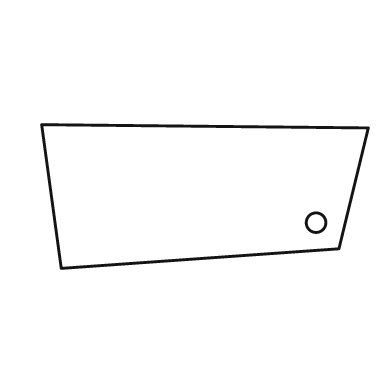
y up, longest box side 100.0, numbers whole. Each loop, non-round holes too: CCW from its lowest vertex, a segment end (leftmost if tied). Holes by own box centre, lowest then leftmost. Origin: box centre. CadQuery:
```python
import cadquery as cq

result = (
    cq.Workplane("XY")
    .moveTo(-44.0, -22.0)
    .lineTo(41.0, -16.0)
    .lineTo(50.0, 21.0)
    .lineTo(-50.0, 22.0)
    .close()
    .moveTo(34.0, -8.0)
    .circle(3.0)
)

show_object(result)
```